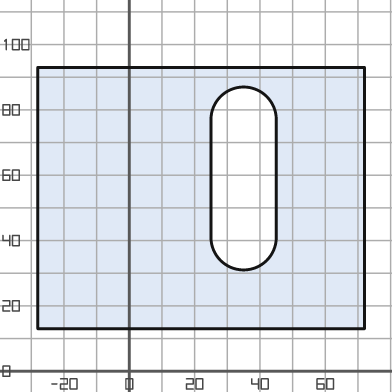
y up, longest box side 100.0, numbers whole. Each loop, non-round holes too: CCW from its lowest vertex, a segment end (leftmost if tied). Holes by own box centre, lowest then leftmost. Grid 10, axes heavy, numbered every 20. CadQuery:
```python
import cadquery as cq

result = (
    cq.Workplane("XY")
    .moveTo(-28.0, 13.0)
    .lineTo(72.0, 13.0)
    .lineTo(72.0, 93.0)
    .lineTo(-28.0, 93.0)
    .close()
    .moveTo(25.0, 41.0)
    .threePointArc((35.0, 31.0), (45.0, 41.0))
    .lineTo(45.0, 77.0)
    .threePointArc((35.0, 87.0), (25.0, 77.0))
    .close()
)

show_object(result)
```